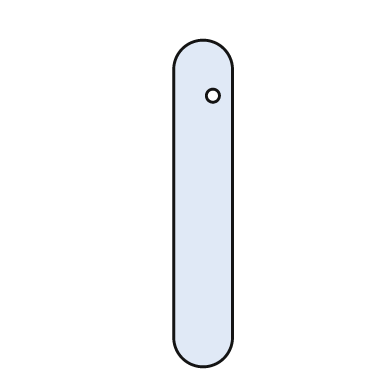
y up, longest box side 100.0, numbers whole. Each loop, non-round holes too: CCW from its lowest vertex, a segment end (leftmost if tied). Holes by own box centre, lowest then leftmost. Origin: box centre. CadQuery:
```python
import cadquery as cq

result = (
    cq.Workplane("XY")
    .moveTo(-9.0, -41.0)
    .threePointArc((0.0, -50.0), (9.0, -41.0))
    .lineTo(9.0, 41.0)
    .threePointArc((0.0, 50.0), (-9.0, 41.0))
    .close()
    .moveTo(3.0, 33.0)
    .circle(2.0)
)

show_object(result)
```